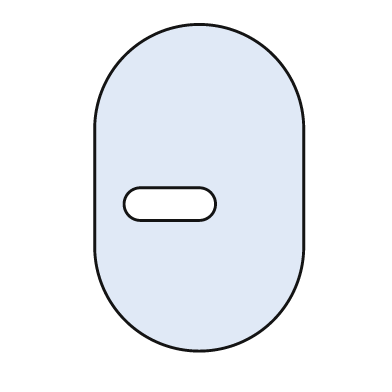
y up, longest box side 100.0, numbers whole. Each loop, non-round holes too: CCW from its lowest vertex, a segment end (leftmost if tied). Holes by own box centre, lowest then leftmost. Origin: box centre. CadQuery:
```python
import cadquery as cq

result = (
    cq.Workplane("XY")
    .moveTo(-32.0, -18.0)
    .threePointArc((0.0, -50.0), (32.0, -18.0))
    .lineTo(32.0, 18.0)
    .threePointArc((0.0, 50.0), (-32.0, 18.0))
    .close()
    .moveTo(-18.0, -10.0)
    .lineTo(0.0, -10.0)
    .threePointArc((5.0, -5.0), (0.0, 0.0))
    .lineTo(-18.0, 0.0)
    .threePointArc((-23.0, -5.0), (-18.0, -10.0))
    .close()
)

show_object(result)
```